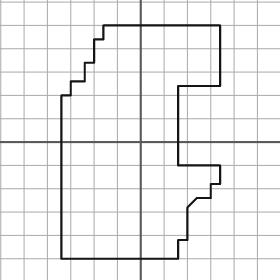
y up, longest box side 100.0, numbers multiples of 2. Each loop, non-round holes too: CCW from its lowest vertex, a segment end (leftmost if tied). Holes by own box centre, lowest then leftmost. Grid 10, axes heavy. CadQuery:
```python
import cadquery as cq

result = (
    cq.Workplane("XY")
    .moveTo(-34.0, -50.0)
    .lineTo(16.0, -50.0)
    .lineTo(16.0, -42.0)
    .lineTo(20.0, -42.0)
    .lineTo(20.0, -28.0)
    .lineTo(24.0, -24.0)
    .lineTo(30.0, -24.0)
    .lineTo(30.0, -18.0)
    .lineTo(34.0, -18.0)
    .lineTo(34.0, -10.0)
    .lineTo(16.0, -10.0)
    .lineTo(16.0, 24.0)
    .lineTo(34.0, 24.0)
    .lineTo(34.0, 50.0)
    .lineTo(-16.0, 50.0)
    .lineTo(-16.0, 44.0)
    .lineTo(-20.0, 44.0)
    .lineTo(-20.0, 34.0)
    .lineTo(-24.0, 34.0)
    .lineTo(-24.0, 26.0)
    .lineTo(-30.0, 26.0)
    .lineTo(-30.0, 20.0)
    .lineTo(-34.0, 20.0)
    .close()
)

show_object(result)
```